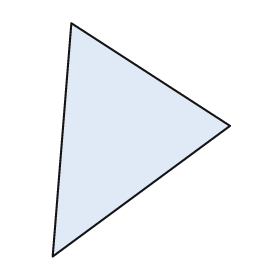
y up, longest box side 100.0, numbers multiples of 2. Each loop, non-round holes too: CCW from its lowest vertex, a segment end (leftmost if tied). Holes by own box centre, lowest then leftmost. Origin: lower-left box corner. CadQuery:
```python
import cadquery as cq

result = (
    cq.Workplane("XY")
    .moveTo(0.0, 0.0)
    .lineTo(76.0, 56.0)
    .lineTo(8.0, 100.0)
    .close()
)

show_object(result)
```